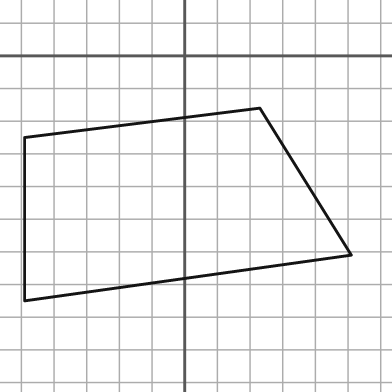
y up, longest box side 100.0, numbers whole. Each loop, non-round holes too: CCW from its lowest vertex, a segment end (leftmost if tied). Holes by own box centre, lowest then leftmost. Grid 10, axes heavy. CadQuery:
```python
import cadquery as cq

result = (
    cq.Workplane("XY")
    .moveTo(-49.0, -75.0)
    .lineTo(51.0, -61.0)
    .lineTo(23.0, -16.0)
    .lineTo(-49.0, -25.0)
    .close()
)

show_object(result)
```